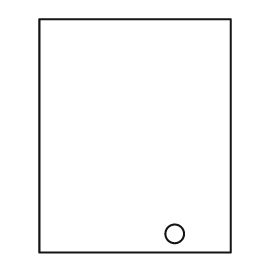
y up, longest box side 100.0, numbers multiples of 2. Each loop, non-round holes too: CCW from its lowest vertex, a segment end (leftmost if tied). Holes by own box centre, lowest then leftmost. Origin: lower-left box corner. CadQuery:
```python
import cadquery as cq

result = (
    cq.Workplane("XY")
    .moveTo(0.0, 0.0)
    .lineTo(82.0, 0.0)
    .lineTo(82.0, 100.0)
    .lineTo(0.0, 100.0)
    .close()
    .moveTo(58.0, 8.0)
    .circle(4.0)
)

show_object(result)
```